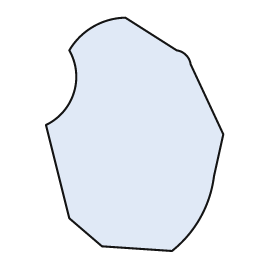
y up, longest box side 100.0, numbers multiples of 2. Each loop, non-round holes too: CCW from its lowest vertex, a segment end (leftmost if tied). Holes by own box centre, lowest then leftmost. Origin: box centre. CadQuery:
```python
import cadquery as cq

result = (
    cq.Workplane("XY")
    .moveTo(16.0, -50.0)
    .threePointArc((28.0, -36.0), (34.0, -18.0))
    .lineTo(38.0, 0.0)
    .lineTo(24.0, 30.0)
    .threePointArc((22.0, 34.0), (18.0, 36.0))
    .lineTo(-4.0, 50.0)
    .threePointArc((-18.0, 46.0), (-28.0, 36.0))
    .threePointArc((-26.0, 18.0), (-38.0, 4.0))
    .lineTo(-28.0, -36.0)
    .lineTo(-14.0, -48.0)
    .close()
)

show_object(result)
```